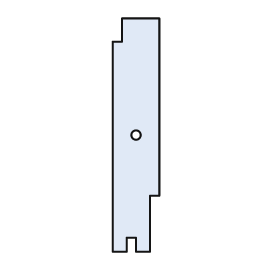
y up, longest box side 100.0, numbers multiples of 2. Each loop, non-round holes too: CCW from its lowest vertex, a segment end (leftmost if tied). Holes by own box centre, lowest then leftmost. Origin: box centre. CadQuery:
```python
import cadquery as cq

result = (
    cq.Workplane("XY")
    .moveTo(-10.0, -50.0)
    .lineTo(-4.0, -50.0)
    .lineTo(-4.0, -44.0)
    .lineTo(0.0, -44.0)
    .lineTo(0.0, -50.0)
    .lineTo(6.0, -50.0)
    .lineTo(6.0, -26.0)
    .lineTo(10.0, -26.0)
    .lineTo(10.0, 50.0)
    .lineTo(-6.0, 50.0)
    .lineTo(-6.0, 40.0)
    .lineTo(-10.0, 40.0)
    .close()
    .moveTo(0.0, 0.0)
    .circle(2.0)
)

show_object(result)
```